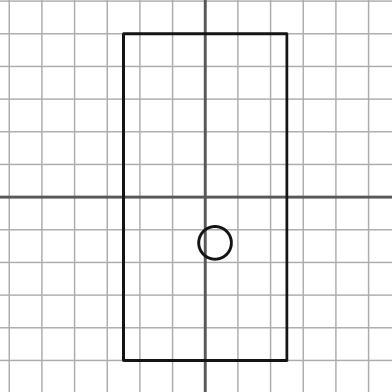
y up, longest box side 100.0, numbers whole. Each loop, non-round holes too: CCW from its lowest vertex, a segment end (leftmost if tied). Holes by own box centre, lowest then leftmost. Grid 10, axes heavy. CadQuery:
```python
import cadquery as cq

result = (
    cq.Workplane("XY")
    .moveTo(-25.0, -50.0)
    .lineTo(25.0, -50.0)
    .lineTo(25.0, 50.0)
    .lineTo(-25.0, 50.0)
    .close()
    .moveTo(3.0, -14.0)
    .circle(5.0)
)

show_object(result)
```